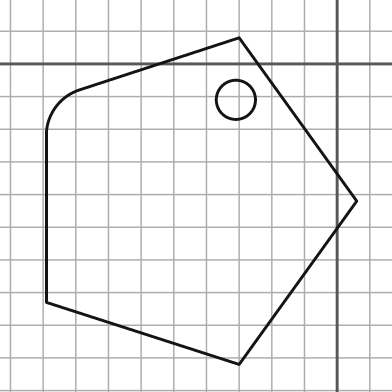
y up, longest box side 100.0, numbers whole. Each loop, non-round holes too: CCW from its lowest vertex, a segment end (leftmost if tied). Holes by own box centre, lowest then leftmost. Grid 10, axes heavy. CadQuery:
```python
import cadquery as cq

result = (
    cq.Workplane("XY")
    .moveTo(-30.0, -92.0)
    .lineTo(6.0, -42.0)
    .lineTo(-30.0, 8.0)
    .lineTo(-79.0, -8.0)
    .threePointArc((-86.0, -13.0), (-89.0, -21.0))
    .lineTo(-89.0, -73.0)
    .close()
    .moveTo(-31.0, -11.0)
    .circle(6.0)
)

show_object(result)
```